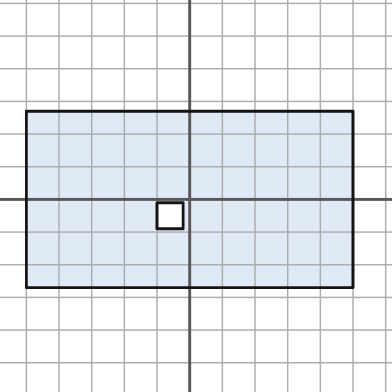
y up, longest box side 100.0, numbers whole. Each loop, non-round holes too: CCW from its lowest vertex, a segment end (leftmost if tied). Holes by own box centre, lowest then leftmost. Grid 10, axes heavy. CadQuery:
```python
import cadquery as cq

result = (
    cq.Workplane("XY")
    .moveTo(-50.0, -27.0)
    .lineTo(50.0, -27.0)
    .lineTo(50.0, 27.0)
    .lineTo(-50.0, 27.0)
    .close()
    .moveTo(-10.0, -9.0)
    .lineTo(-2.0, -9.0)
    .lineTo(-2.0, -1.0)
    .lineTo(-10.0, -1.0)
    .close()
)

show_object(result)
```